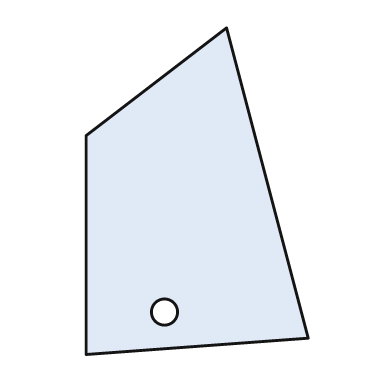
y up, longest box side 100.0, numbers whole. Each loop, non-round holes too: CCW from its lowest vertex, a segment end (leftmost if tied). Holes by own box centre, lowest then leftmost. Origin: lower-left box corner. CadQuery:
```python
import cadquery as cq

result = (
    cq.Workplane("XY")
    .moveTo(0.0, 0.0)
    .lineTo(68.0, 5.0)
    .lineTo(43.0, 100.0)
    .lineTo(0.0, 67.0)
    .close()
    .moveTo(24.0, 13.0)
    .circle(4.0)
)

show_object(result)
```